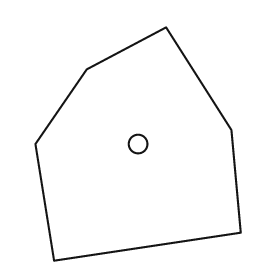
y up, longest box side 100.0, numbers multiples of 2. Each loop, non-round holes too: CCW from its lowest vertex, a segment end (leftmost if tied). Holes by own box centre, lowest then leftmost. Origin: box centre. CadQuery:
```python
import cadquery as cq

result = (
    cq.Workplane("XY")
    .moveTo(-36.0, -50.0)
    .lineTo(44.0, -38.0)
    .lineTo(40.0, 6.0)
    .lineTo(12.0, 50.0)
    .lineTo(-22.0, 32.0)
    .lineTo(-44.0, 0.0)
    .close()
    .moveTo(0.0, 0.0)
    .circle(4.0)
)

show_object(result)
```